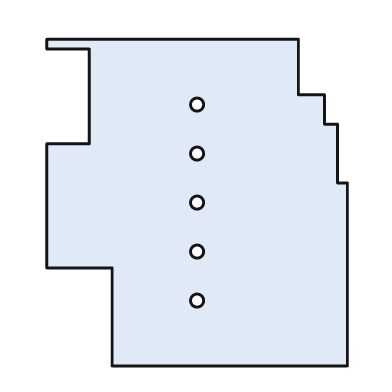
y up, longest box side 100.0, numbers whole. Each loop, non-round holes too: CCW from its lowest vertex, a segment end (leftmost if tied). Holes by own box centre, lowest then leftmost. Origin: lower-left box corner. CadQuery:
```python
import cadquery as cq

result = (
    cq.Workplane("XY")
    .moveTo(20.0, 0.0)
    .lineTo(92.0, 0.0)
    .lineTo(92.0, 56.0)
    .lineTo(89.0, 56.0)
    .lineTo(89.0, 74.0)
    .lineTo(85.0, 74.0)
    .lineTo(85.0, 83.0)
    .lineTo(77.0, 83.0)
    .lineTo(77.0, 100.0)
    .lineTo(0.0, 100.0)
    .lineTo(0.0, 97.0)
    .lineTo(13.0, 97.0)
    .lineTo(13.0, 68.0)
    .lineTo(0.0, 68.0)
    .lineTo(0.0, 30.0)
    .lineTo(20.0, 30.0)
    .close()
    .moveTo(46.0, 20.0)
    .circle(2.0)
    .moveTo(46.0, 35.0)
    .circle(2.0)
    .moveTo(46.0, 50.0)
    .circle(2.0)
    .moveTo(46.0, 65.0)
    .circle(2.0)
    .moveTo(46.0, 80.0)
    .circle(2.0)
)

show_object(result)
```